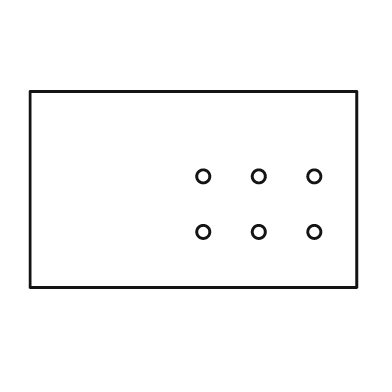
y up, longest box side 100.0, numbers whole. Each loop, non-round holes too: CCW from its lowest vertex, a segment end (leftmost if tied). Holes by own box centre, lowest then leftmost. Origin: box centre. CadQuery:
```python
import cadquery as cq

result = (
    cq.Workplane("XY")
    .moveTo(-50.0, -30.0)
    .lineTo(50.0, -30.0)
    .lineTo(50.0, 30.0)
    .lineTo(-50.0, 30.0)
    .close()
    .moveTo(3.0, -13.0)
    .circle(2.0)
    .moveTo(20.0, -13.0)
    .circle(2.0)
    .moveTo(37.0, -13.0)
    .circle(2.0)
    .moveTo(3.0, 4.0)
    .circle(2.0)
    .moveTo(20.0, 4.0)
    .circle(2.0)
    .moveTo(37.0, 4.0)
    .circle(2.0)
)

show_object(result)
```